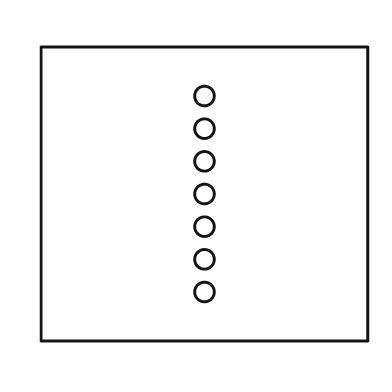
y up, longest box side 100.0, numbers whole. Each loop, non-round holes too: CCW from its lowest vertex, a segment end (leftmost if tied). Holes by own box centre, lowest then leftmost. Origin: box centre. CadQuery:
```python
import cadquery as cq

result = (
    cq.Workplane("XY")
    .moveTo(-50.0, -45.0)
    .lineTo(50.0, -45.0)
    .lineTo(50.0, 45.0)
    .lineTo(-50.0, 45.0)
    .close()
    .moveTo(0.0, -30.0)
    .circle(3.0)
    .moveTo(0.0, -20.0)
    .circle(3.0)
    .moveTo(0.0, -10.0)
    .circle(3.0)
    .moveTo(0.0, 0.0)
    .circle(3.0)
    .moveTo(0.0, 10.0)
    .circle(3.0)
    .moveTo(0.0, 20.0)
    .circle(3.0)
    .moveTo(0.0, 30.0)
    .circle(3.0)
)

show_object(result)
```